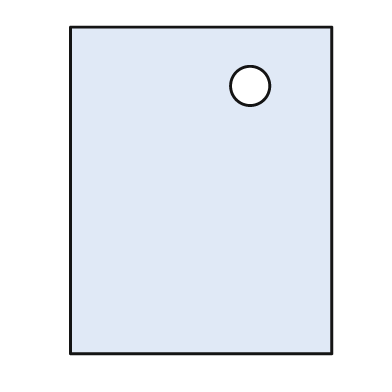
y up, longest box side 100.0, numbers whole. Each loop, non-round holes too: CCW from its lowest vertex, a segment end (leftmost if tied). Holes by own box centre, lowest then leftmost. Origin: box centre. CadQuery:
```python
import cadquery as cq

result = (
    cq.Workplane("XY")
    .moveTo(-40.0, -50.0)
    .lineTo(40.0, -50.0)
    .lineTo(40.0, 50.0)
    .lineTo(-40.0, 50.0)
    .close()
    .moveTo(15.0, 32.0)
    .circle(6.0)
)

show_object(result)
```